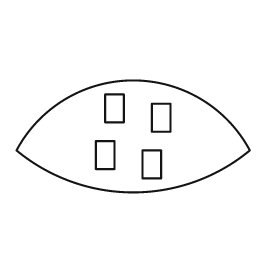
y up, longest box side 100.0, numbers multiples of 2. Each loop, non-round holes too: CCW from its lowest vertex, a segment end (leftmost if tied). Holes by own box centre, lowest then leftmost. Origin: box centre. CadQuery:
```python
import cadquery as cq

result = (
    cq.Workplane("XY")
    .moveTo(-50.0, -6.0)
    .threePointArc((0.0, -24.0), (50.0, -6.0))
    .threePointArc((0.0, 24.0), (-50.0, -6.0))
    .close()
    .moveTo(4.0, -18.0)
    .lineTo(12.0, -18.0)
    .lineTo(12.0, -6.0)
    .lineTo(4.0, -6.0)
    .close()
    .moveTo(-16.0, -14.0)
    .lineTo(-8.0, -14.0)
    .lineTo(-8.0, -2.0)
    .lineTo(-16.0, -2.0)
    .close()
    .moveTo(8.0, 2.0)
    .lineTo(16.0, 2.0)
    .lineTo(16.0, 14.0)
    .lineTo(8.0, 14.0)
    .close()
    .moveTo(-12.0, 6.0)
    .lineTo(-4.0, 6.0)
    .lineTo(-4.0, 18.0)
    .lineTo(-12.0, 18.0)
    .close()
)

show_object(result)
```